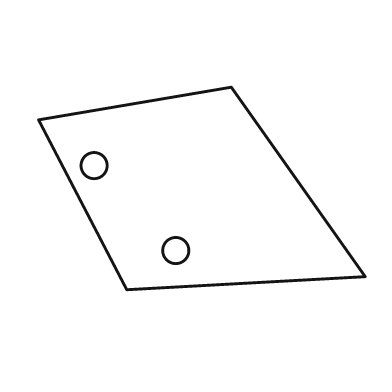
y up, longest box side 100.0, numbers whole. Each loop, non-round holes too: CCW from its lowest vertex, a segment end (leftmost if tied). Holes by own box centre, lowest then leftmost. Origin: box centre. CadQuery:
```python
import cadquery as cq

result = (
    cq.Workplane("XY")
    .moveTo(-23.0, -31.0)
    .lineTo(50.0, -27.0)
    .lineTo(9.0, 31.0)
    .lineTo(-50.0, 21.0)
    .close()
    .moveTo(-8.0, -19.0)
    .circle(4.0)
    .moveTo(-33.0, 7.0)
    .circle(4.0)
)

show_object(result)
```